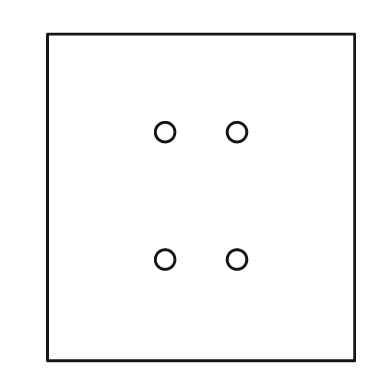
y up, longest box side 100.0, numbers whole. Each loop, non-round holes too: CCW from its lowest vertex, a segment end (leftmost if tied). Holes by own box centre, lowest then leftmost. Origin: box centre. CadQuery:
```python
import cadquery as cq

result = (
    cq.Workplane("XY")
    .moveTo(-47.0, -50.0)
    .lineTo(47.0, -50.0)
    .lineTo(47.0, 50.0)
    .lineTo(-47.0, 50.0)
    .close()
    .moveTo(-11.0, -19.0)
    .circle(3.0)
    .moveTo(11.0, -19.0)
    .circle(3.0)
    .moveTo(-11.0, 20.0)
    .circle(3.0)
    .moveTo(11.0, 20.0)
    .circle(3.0)
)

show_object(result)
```